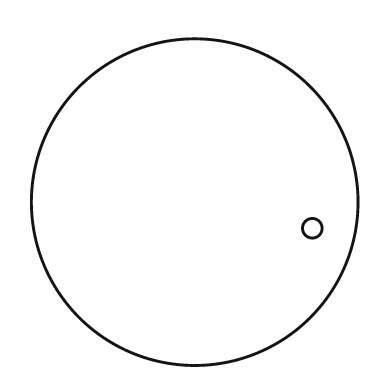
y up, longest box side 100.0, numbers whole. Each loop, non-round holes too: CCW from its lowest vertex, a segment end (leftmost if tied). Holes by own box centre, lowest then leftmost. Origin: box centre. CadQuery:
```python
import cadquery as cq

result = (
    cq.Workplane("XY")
    .moveTo(0.0, 0.0)
    .circle(50.0)
    .moveTo(36.0, -8.0)
    .circle(3.0)
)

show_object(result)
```